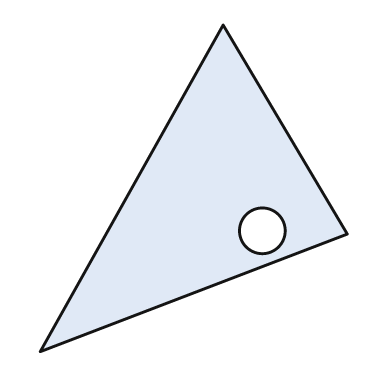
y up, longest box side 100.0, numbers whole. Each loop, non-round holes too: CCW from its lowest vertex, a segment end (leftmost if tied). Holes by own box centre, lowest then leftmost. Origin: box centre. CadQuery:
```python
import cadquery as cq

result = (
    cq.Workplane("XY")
    .moveTo(-47.0, -50.0)
    .lineTo(47.0, -14.0)
    .lineTo(9.0, 50.0)
    .close()
    .moveTo(21.0, -13.0)
    .circle(7.0)
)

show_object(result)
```